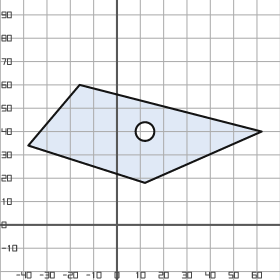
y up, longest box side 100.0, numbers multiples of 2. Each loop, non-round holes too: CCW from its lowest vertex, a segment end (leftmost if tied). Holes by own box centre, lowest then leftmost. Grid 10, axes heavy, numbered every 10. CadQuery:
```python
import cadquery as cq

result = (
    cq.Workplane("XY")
    .moveTo(12.0, 18.0)
    .lineTo(62.0, 40.0)
    .lineTo(-16.0, 60.0)
    .lineTo(-38.0, 34.0)
    .close()
    .moveTo(12.0, 40.0)
    .circle(4.0)
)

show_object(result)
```